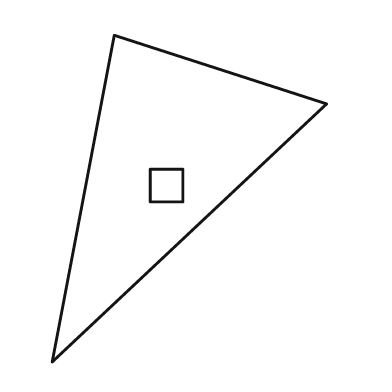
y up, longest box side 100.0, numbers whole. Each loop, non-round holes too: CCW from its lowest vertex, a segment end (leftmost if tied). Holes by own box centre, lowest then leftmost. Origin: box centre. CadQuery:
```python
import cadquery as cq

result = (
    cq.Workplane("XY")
    .moveTo(-42.0, -50.0)
    .lineTo(42.0, 29.0)
    .lineTo(-23.0, 50.0)
    .close()
    .moveTo(-12.0, -1.0)
    .lineTo(-2.0, -1.0)
    .lineTo(-2.0, 9.0)
    .lineTo(-12.0, 9.0)
    .close()
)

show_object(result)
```